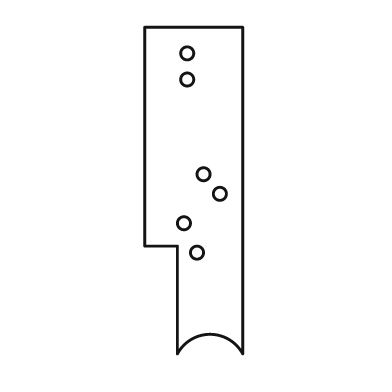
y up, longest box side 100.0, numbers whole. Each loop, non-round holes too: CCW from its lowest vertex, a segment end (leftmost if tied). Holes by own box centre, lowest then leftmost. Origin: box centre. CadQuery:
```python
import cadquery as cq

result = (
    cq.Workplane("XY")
    .moveTo(-5.0, -50.0)
    .threePointArc((5.0, -44.0), (15.0, -50.0))
    .lineTo(15.0, 50.0)
    .lineTo(-15.0, 50.0)
    .lineTo(-15.0, -17.0)
    .lineTo(-5.0, -17.0)
    .close()
    .moveTo(1.0, -19.0)
    .circle(2.0)
    .moveTo(-3.0, -10.0)
    .circle(2.0)
    .moveTo(8.0, -1.0)
    .circle(2.0)
    .moveTo(3.0, 5.0)
    .circle(2.0)
    .moveTo(-2.0, 34.0)
    .circle(2.0)
    .moveTo(-2.0, 42.0)
    .circle(2.0)
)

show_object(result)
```